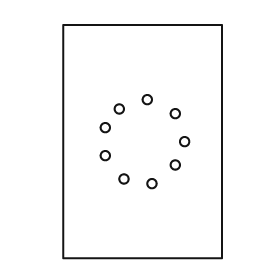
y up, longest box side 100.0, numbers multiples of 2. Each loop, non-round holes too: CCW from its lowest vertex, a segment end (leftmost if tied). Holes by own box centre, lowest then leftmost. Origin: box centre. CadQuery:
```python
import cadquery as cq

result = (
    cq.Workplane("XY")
    .moveTo(-34.0, -50.0)
    .lineTo(34.0, -50.0)
    .lineTo(34.0, 50.0)
    .lineTo(-34.0, 50.0)
    .close()
    .moveTo(4.0, -18.0)
    .circle(2.0)
    .moveTo(-8.0, -16.0)
    .circle(2.0)
    .moveTo(14.0, -10.0)
    .circle(2.0)
    .moveTo(-16.0, -6.0)
    .circle(2.0)
    .moveTo(18.0, 0.0)
    .circle(2.0)
    .moveTo(-16.0, 6.0)
    .circle(2.0)
    .moveTo(14.0, 12.0)
    .circle(2.0)
    .moveTo(-10.0, 14.0)
    .circle(2.0)
    .moveTo(2.0, 18.0)
    .circle(2.0)
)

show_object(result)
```